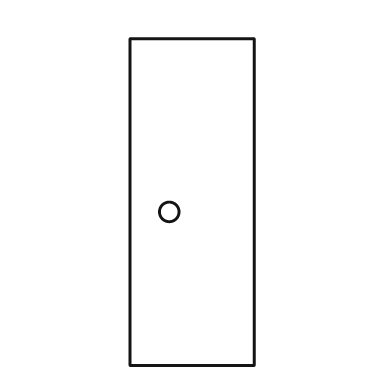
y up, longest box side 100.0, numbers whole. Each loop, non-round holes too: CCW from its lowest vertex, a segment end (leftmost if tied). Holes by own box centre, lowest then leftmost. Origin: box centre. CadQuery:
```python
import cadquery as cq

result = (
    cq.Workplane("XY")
    .moveTo(-19.0, -50.0)
    .lineTo(19.0, -50.0)
    .lineTo(19.0, 50.0)
    .lineTo(-19.0, 50.0)
    .close()
    .moveTo(-7.0, -3.0)
    .circle(3.0)
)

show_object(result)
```